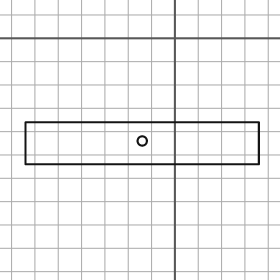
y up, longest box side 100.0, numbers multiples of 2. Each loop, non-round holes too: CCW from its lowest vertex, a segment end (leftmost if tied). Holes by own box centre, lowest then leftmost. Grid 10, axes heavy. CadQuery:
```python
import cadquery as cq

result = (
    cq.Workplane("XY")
    .moveTo(-64.0, -54.0)
    .lineTo(36.0, -54.0)
    .lineTo(36.0, -36.0)
    .lineTo(-64.0, -36.0)
    .close()
    .moveTo(-14.0, -44.0)
    .circle(2.0)
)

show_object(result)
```